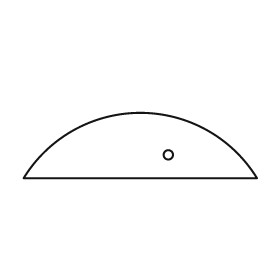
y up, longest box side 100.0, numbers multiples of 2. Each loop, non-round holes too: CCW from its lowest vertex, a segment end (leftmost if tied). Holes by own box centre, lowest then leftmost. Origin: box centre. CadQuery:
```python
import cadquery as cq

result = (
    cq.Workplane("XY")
    .moveTo(-50.0, -14.0)
    .lineTo(50.0, -14.0)
    .threePointArc((0.0, 14.0), (-50.0, -14.0))
    .close()
    .moveTo(12.0, -4.0)
    .circle(2.0)
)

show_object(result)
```